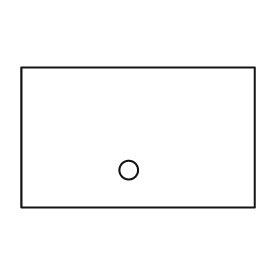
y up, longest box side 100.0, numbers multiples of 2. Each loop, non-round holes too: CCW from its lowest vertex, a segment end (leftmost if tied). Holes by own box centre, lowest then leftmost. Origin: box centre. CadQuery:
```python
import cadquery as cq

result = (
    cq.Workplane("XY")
    .moveTo(-50.0, -30.0)
    .lineTo(50.0, -30.0)
    .lineTo(50.0, 30.0)
    .lineTo(-50.0, 30.0)
    .close()
    .moveTo(-4.0, -14.0)
    .circle(4.0)
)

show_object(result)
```